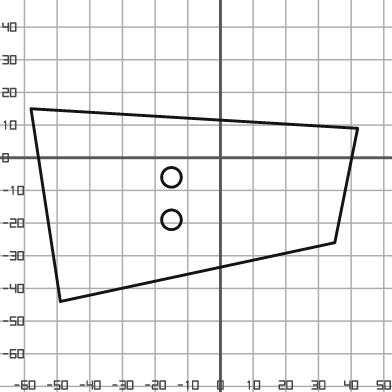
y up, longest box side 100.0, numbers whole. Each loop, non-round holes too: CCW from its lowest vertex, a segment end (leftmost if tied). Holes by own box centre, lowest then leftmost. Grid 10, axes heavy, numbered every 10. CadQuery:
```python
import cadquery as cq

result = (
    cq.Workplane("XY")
    .moveTo(-49.0, -44.0)
    .lineTo(35.0, -26.0)
    .lineTo(42.0, 9.0)
    .lineTo(-58.0, 15.0)
    .close()
    .moveTo(-15.0, -19.0)
    .circle(3.0)
    .moveTo(-15.0, -6.0)
    .circle(3.0)
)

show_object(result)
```